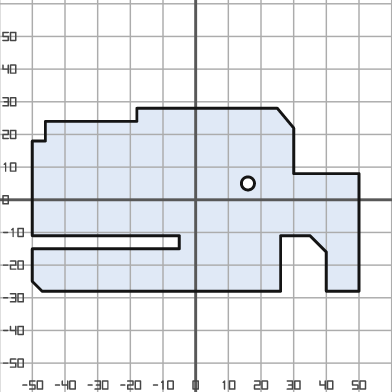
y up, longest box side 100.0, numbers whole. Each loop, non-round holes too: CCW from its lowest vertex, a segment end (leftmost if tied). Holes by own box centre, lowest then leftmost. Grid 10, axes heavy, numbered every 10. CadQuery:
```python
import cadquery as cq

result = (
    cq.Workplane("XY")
    .moveTo(-47.0, -28.0)
    .lineTo(26.0, -28.0)
    .lineTo(26.0, -11.0)
    .lineTo(35.0, -11.0)
    .lineTo(40.0, -16.0)
    .lineTo(40.0, -28.0)
    .lineTo(50.0, -28.0)
    .lineTo(50.0, 8.0)
    .lineTo(30.0, 8.0)
    .lineTo(30.0, 22.0)
    .lineTo(25.0, 28.0)
    .lineTo(-18.0, 28.0)
    .lineTo(-18.0, 24.0)
    .lineTo(-46.0, 24.0)
    .lineTo(-46.0, 18.0)
    .lineTo(-50.0, 18.0)
    .lineTo(-50.0, -11.0)
    .lineTo(-5.0, -11.0)
    .lineTo(-5.0, -15.0)
    .lineTo(-50.0, -15.0)
    .lineTo(-50.0, -25.0)
    .close()
    .moveTo(16.0, 5.0)
    .circle(2.0)
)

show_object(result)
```